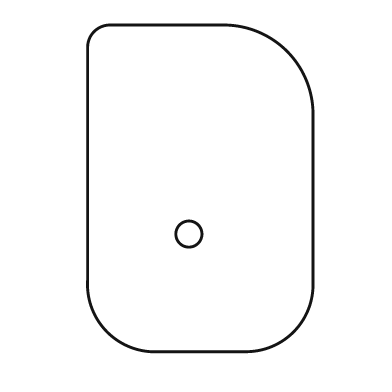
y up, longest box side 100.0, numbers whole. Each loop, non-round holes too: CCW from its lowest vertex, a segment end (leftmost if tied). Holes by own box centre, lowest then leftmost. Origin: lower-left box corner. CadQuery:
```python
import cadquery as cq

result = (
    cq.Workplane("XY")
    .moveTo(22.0, 0.0)
    .lineTo(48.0, 0.0)
    .threePointArc((63.0, 6.0), (69.0, 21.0))
    .lineTo(69.0, 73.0)
    .threePointArc((61.0, 92.0), (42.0, 100.0))
    .lineTo(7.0, 100.0)
    .threePointArc((2.0, 98.0), (0.0, 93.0))
    .lineTo(0.0, 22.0)
    .threePointArc((6.0, 6.0), (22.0, 0.0))
    .close()
    .moveTo(31.0, 36.0)
    .circle(4.0)
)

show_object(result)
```